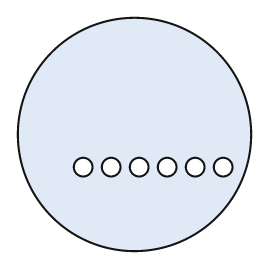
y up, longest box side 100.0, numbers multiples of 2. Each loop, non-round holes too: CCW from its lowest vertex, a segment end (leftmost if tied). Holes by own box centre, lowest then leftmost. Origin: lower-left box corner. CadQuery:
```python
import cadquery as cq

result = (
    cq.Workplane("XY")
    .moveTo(50.0, 50.0)
    .circle(50.0)
    .moveTo(28.0, 36.0)
    .circle(4.0)
    .moveTo(40.0, 36.0)
    .circle(4.0)
    .moveTo(52.0, 36.0)
    .circle(4.0)
    .moveTo(64.0, 36.0)
    .circle(4.0)
    .moveTo(76.0, 36.0)
    .circle(4.0)
    .moveTo(88.0, 36.0)
    .circle(4.0)
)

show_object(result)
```